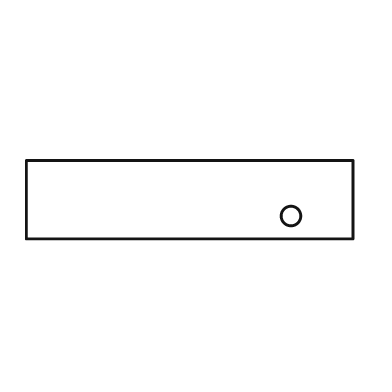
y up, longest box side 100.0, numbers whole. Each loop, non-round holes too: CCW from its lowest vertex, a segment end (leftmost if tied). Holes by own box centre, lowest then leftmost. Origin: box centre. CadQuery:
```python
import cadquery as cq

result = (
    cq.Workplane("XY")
    .moveTo(-50.0, -12.0)
    .lineTo(50.0, -12.0)
    .lineTo(50.0, 12.0)
    .lineTo(-50.0, 12.0)
    .close()
    .moveTo(31.0, -5.0)
    .circle(3.0)
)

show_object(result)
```